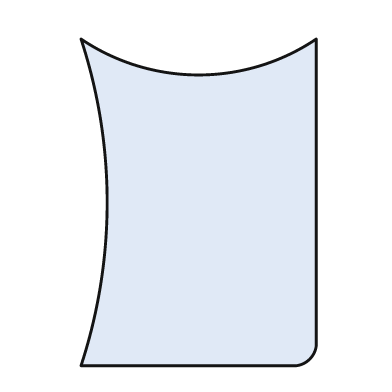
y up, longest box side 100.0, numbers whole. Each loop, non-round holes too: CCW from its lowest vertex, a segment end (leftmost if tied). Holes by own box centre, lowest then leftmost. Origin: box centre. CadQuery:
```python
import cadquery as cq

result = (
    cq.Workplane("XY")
    .moveTo(-36.0, -50.0)
    .lineTo(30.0, -50.0)
    .threePointArc((34.0, -48.0), (36.0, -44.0))
    .lineTo(36.0, 50.0)
    .threePointArc((0.0, 39.0), (-36.0, 50.0))
    .threePointArc((-28.0, 0.0), (-36.0, -50.0))
    .close()
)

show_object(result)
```